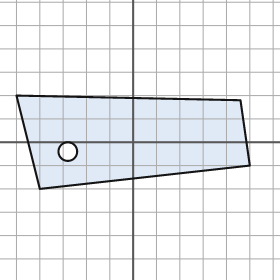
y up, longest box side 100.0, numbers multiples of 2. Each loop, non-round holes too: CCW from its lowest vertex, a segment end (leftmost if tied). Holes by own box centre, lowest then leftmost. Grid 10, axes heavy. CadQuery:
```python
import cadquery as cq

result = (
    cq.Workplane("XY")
    .moveTo(-40.0, -20.0)
    .lineTo(50.0, -10.0)
    .lineTo(46.0, 18.0)
    .lineTo(-50.0, 20.0)
    .close()
    .moveTo(-28.0, -4.0)
    .circle(4.0)
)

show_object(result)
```